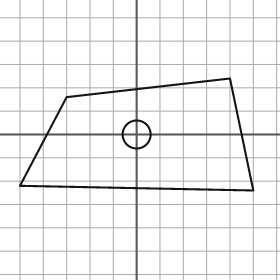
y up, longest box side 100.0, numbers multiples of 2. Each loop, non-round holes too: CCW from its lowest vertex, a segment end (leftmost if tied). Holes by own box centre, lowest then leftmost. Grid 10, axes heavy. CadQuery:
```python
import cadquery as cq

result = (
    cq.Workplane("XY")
    .moveTo(50.0, -24.0)
    .lineTo(40.0, 24.0)
    .lineTo(-30.0, 16.0)
    .lineTo(-50.0, -22.0)
    .close()
    .moveTo(0.0, 0.0)
    .circle(6.0)
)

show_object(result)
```